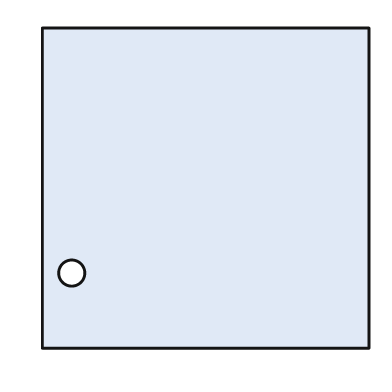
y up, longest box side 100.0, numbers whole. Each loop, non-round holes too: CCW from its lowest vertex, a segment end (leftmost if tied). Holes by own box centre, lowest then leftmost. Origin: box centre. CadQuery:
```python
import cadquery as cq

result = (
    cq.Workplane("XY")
    .moveTo(-50.0, -49.0)
    .lineTo(50.0, -49.0)
    .lineTo(50.0, 49.0)
    .lineTo(-50.0, 49.0)
    .close()
    .moveTo(-41.0, -26.0)
    .circle(4.0)
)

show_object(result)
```